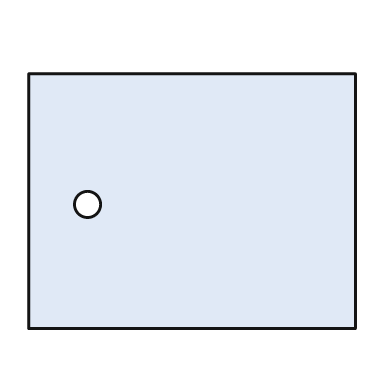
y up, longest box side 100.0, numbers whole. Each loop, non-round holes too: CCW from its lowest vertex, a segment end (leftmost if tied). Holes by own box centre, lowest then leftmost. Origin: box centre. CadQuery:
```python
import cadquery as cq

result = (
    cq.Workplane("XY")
    .moveTo(-50.0, -39.0)
    .lineTo(50.0, -39.0)
    .lineTo(50.0, 39.0)
    .lineTo(-50.0, 39.0)
    .close()
    .moveTo(-32.0, -1.0)
    .circle(4.0)
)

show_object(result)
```